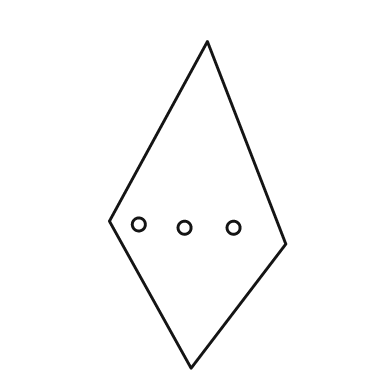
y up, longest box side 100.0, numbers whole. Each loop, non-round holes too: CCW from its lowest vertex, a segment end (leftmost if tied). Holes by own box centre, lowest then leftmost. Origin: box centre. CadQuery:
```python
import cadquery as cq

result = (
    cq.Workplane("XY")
    .moveTo(-2.0, -50.0)
    .lineTo(27.0, -12.0)
    .lineTo(3.0, 50.0)
    .lineTo(-27.0, -5.0)
    .close()
    .moveTo(-4.0, -7.0)
    .circle(2.0)
    .moveTo(11.0, -7.0)
    .circle(2.0)
    .moveTo(-18.0, -6.0)
    .circle(2.0)
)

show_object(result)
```